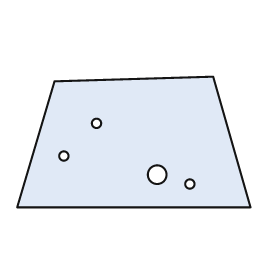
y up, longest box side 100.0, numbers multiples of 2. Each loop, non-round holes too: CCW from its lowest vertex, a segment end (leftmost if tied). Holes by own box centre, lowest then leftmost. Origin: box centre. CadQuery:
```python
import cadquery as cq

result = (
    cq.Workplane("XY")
    .moveTo(-50.0, -28.0)
    .lineTo(50.0, -28.0)
    .lineTo(34.0, 28.0)
    .lineTo(-34.0, 26.0)
    .close()
    .moveTo(24.0, -18.0)
    .circle(2.0)
    .moveTo(10.0, -14.0)
    .circle(4.0)
    .moveTo(-30.0, -6.0)
    .circle(2.0)
    .moveTo(-16.0, 8.0)
    .circle(2.0)
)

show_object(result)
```